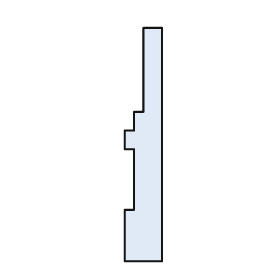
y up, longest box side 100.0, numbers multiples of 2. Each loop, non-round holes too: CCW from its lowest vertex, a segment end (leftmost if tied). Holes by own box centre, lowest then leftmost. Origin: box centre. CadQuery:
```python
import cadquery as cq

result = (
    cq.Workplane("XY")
    .moveTo(-8.0, -50.0)
    .lineTo(8.0, -50.0)
    .lineTo(8.0, 50.0)
    .lineTo(0.0, 50.0)
    .lineTo(0.0, 14.0)
    .lineTo(-4.0, 14.0)
    .lineTo(-4.0, 6.0)
    .lineTo(-8.0, 6.0)
    .lineTo(-8.0, -2.0)
    .lineTo(-4.0, -2.0)
    .lineTo(-4.0, -28.0)
    .lineTo(-8.0, -28.0)
    .close()
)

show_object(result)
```